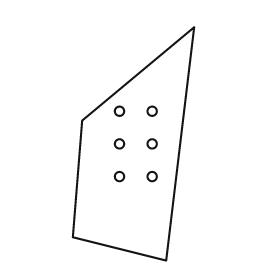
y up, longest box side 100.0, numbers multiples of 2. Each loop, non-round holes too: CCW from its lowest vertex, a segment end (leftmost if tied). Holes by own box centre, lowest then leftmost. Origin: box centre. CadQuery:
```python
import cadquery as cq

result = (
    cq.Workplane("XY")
    .moveTo(14.0, -50.0)
    .lineTo(26.0, 50.0)
    .lineTo(-22.0, 10.0)
    .lineTo(-26.0, -40.0)
    .close()
    .moveTo(-6.0, -14.0)
    .circle(2.0)
    .moveTo(8.0, -14.0)
    .circle(2.0)
    .moveTo(-6.0, 0.0)
    .circle(2.0)
    .moveTo(8.0, 0.0)
    .circle(2.0)
    .moveTo(-6.0, 14.0)
    .circle(2.0)
    .moveTo(8.0, 14.0)
    .circle(2.0)
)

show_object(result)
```